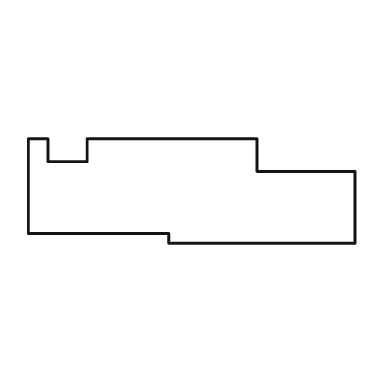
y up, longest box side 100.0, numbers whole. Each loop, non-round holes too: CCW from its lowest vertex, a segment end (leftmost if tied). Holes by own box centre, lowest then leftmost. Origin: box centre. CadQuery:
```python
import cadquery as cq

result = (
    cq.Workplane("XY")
    .moveTo(-7.0, -16.0)
    .lineTo(50.0, -16.0)
    .lineTo(50.0, 6.0)
    .lineTo(20.0, 6.0)
    .lineTo(20.0, 16.0)
    .lineTo(-32.0, 16.0)
    .lineTo(-32.0, 9.0)
    .lineTo(-44.0, 9.0)
    .lineTo(-44.0, 16.0)
    .lineTo(-50.0, 16.0)
    .lineTo(-50.0, -13.0)
    .lineTo(-7.0, -13.0)
    .close()
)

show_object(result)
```